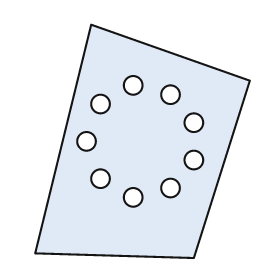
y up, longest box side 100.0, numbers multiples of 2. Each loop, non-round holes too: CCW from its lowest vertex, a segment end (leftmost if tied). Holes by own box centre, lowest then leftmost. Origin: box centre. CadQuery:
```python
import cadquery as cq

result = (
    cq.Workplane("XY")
    .moveTo(22.0, -50.0)
    .lineTo(46.0, 26.0)
    .lineTo(-22.0, 50.0)
    .lineTo(-46.0, -48.0)
    .close()
    .moveTo(-4.0, -24.0)
    .circle(4.0)
    .moveTo(12.0, -20.0)
    .circle(4.0)
    .moveTo(-18.0, -16.0)
    .circle(4.0)
    .moveTo(22.0, -8.0)
    .circle(4.0)
    .moveTo(-24.0, 0.0)
    .circle(4.0)
    .moveTo(22.0, 8.0)
    .circle(4.0)
    .moveTo(-18.0, 16.0)
    .circle(4.0)
    .moveTo(12.0, 20.0)
    .circle(4.0)
    .moveTo(-4.0, 24.0)
    .circle(4.0)
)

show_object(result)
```